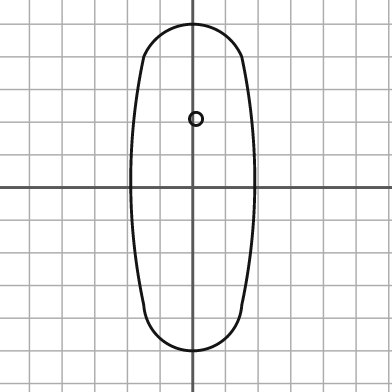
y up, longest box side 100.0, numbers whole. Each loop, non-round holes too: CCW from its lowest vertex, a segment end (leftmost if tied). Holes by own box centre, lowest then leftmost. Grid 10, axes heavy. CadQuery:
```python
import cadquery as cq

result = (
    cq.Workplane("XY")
    .moveTo(-15.0, -36.0)
    .threePointArc((0.0, -50.0), (15.0, -36.0))
    .threePointArc((19.0, 2.0), (15.0, 40.0))
    .threePointArc((0.0, 50.0), (-15.0, 40.0))
    .threePointArc((-19.0, 2.0), (-15.0, -36.0))
    .close()
    .moveTo(1.0, 21.0)
    .circle(2.0)
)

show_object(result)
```